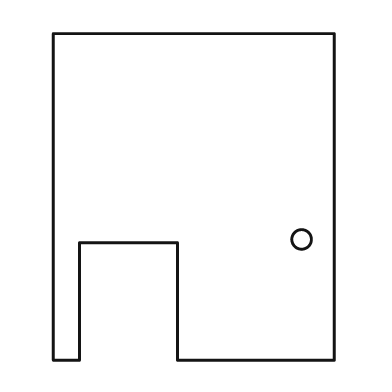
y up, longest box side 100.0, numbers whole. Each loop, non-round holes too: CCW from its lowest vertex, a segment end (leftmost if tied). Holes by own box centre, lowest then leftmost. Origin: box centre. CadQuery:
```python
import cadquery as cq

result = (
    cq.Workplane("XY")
    .moveTo(-43.0, -50.0)
    .lineTo(-35.0, -50.0)
    .lineTo(-35.0, -14.0)
    .lineTo(-5.0, -14.0)
    .lineTo(-5.0, -50.0)
    .lineTo(43.0, -50.0)
    .lineTo(43.0, 50.0)
    .lineTo(-43.0, 50.0)
    .close()
    .moveTo(33.0, -13.0)
    .circle(3.0)
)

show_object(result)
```